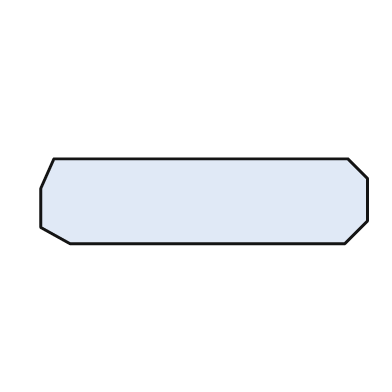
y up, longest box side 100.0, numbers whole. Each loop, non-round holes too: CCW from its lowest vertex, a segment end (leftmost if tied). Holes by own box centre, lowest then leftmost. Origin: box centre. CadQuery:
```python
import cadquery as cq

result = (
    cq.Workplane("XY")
    .moveTo(-41.0, -13.0)
    .lineTo(43.0, -13.0)
    .lineTo(50.0, -6.0)
    .lineTo(50.0, 7.0)
    .lineTo(44.0, 13.0)
    .lineTo(-46.0, 13.0)
    .lineTo(-50.0, 4.0)
    .lineTo(-50.0, -8.0)
    .close()
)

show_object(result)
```